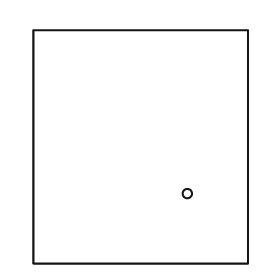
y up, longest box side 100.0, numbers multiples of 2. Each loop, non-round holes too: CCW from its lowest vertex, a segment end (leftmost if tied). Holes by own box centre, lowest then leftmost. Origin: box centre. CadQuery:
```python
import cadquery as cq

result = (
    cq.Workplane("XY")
    .moveTo(-46.0, -50.0)
    .lineTo(46.0, -50.0)
    .lineTo(46.0, 50.0)
    .lineTo(-46.0, 50.0)
    .close()
    .moveTo(20.0, -20.0)
    .circle(2.0)
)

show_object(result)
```